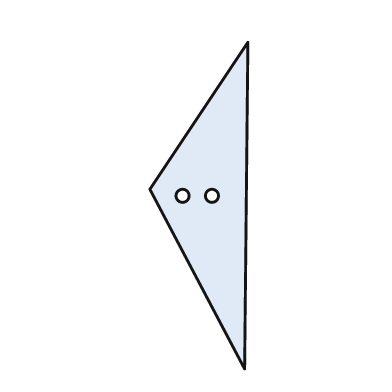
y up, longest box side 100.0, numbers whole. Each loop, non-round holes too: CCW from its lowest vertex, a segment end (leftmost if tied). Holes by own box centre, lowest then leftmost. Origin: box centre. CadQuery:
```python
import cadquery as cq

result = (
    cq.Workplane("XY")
    .moveTo(14.0, -50.0)
    .lineTo(15.0, 50.0)
    .lineTo(-15.0, 5.0)
    .close()
    .moveTo(-5.0, 3.0)
    .circle(2.0)
    .moveTo(4.0, 3.0)
    .circle(2.0)
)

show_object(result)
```